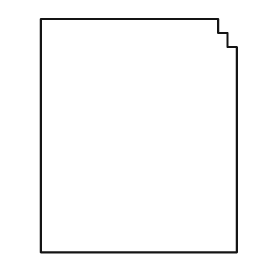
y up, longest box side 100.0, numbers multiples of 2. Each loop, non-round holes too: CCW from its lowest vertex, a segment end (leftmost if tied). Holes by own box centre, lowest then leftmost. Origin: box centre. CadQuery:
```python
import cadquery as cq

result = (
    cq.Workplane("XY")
    .moveTo(-42.0, -50.0)
    .lineTo(42.0, -50.0)
    .lineTo(42.0, 38.0)
    .lineTo(38.0, 38.0)
    .lineTo(38.0, 44.0)
    .lineTo(34.0, 44.0)
    .lineTo(34.0, 50.0)
    .lineTo(-42.0, 50.0)
    .close()
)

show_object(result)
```